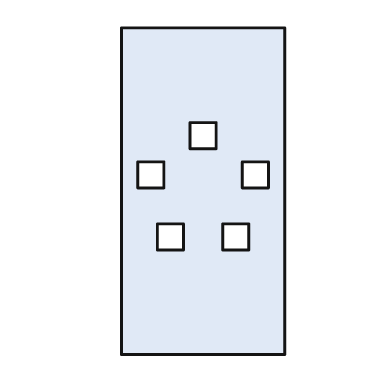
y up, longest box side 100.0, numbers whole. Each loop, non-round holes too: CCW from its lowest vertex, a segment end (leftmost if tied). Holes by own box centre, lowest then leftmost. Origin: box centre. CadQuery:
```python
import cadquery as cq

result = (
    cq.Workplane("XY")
    .moveTo(-25.0, -50.0)
    .lineTo(25.0, -50.0)
    .lineTo(25.0, 50.0)
    .lineTo(-25.0, 50.0)
    .close()
    .moveTo(-14.0, -18.0)
    .lineTo(-6.0, -18.0)
    .lineTo(-6.0, -10.0)
    .lineTo(-14.0, -10.0)
    .close()
    .moveTo(6.0, -18.0)
    .lineTo(14.0, -18.0)
    .lineTo(14.0, -10.0)
    .lineTo(6.0, -10.0)
    .close()
    .moveTo(-20.0, 1.0)
    .lineTo(-12.0, 1.0)
    .lineTo(-12.0, 9.0)
    .lineTo(-20.0, 9.0)
    .close()
    .moveTo(12.0, 1.0)
    .lineTo(20.0, 1.0)
    .lineTo(20.0, 9.0)
    .lineTo(12.0, 9.0)
    .close()
    .moveTo(-4.0, 13.0)
    .lineTo(4.0, 13.0)
    .lineTo(4.0, 21.0)
    .lineTo(-4.0, 21.0)
    .close()
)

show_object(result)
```